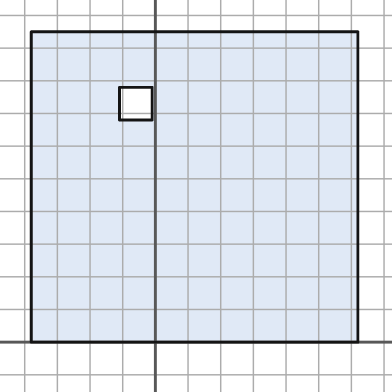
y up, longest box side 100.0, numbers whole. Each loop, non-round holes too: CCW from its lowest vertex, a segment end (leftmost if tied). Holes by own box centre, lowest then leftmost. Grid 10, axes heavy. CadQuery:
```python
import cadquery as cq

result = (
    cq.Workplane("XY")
    .moveTo(-38.0, 0.0)
    .lineTo(62.0, 0.0)
    .lineTo(62.0, 95.0)
    .lineTo(-38.0, 95.0)
    .close()
    .moveTo(-11.0, 68.0)
    .lineTo(-1.0, 68.0)
    .lineTo(-1.0, 78.0)
    .lineTo(-11.0, 78.0)
    .close()
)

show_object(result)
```